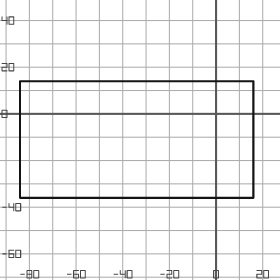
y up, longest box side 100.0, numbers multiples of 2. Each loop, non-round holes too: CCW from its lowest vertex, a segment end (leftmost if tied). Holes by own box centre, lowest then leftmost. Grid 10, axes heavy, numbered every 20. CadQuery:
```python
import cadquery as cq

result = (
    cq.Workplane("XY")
    .moveTo(-84.0, -36.0)
    .lineTo(16.0, -36.0)
    .lineTo(16.0, 14.0)
    .lineTo(-84.0, 14.0)
    .close()
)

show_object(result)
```